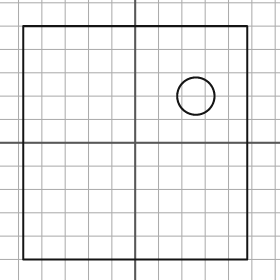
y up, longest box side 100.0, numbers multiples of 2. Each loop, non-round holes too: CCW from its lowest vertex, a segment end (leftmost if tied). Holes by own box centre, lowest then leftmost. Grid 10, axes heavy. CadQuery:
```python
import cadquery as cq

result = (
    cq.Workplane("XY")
    .moveTo(-48.0, -50.0)
    .lineTo(48.0, -50.0)
    .lineTo(48.0, 50.0)
    .lineTo(-48.0, 50.0)
    .close()
    .moveTo(26.0, 20.0)
    .circle(8.0)
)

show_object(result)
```